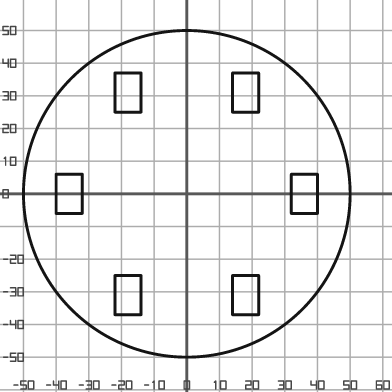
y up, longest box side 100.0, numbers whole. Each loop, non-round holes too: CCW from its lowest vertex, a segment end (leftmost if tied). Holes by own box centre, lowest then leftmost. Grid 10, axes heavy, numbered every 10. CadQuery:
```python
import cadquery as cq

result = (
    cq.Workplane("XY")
    .moveTo(0.0, 0.0)
    .circle(50.0)
    .moveTo(-22.0, -37.0)
    .lineTo(-14.0, -37.0)
    .lineTo(-14.0, -25.0)
    .lineTo(-22.0, -25.0)
    .close()
    .moveTo(14.0, -37.0)
    .lineTo(22.0, -37.0)
    .lineTo(22.0, -25.0)
    .lineTo(14.0, -25.0)
    .close()
    .moveTo(-40.0, -6.0)
    .lineTo(-32.0, -6.0)
    .lineTo(-32.0, 6.0)
    .lineTo(-40.0, 6.0)
    .close()
    .moveTo(32.0, -6.0)
    .lineTo(40.0, -6.0)
    .lineTo(40.0, 6.0)
    .lineTo(32.0, 6.0)
    .close()
    .moveTo(-22.0, 25.0)
    .lineTo(-14.0, 25.0)
    .lineTo(-14.0, 37.0)
    .lineTo(-22.0, 37.0)
    .close()
    .moveTo(14.0, 25.0)
    .lineTo(22.0, 25.0)
    .lineTo(22.0, 37.0)
    .lineTo(14.0, 37.0)
    .close()
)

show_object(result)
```